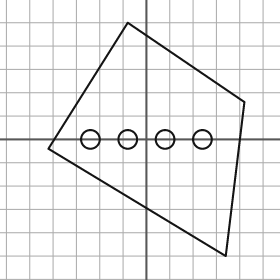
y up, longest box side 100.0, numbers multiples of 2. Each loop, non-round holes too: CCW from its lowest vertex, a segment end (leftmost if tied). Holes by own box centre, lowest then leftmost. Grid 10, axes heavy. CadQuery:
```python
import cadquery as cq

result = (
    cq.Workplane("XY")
    .moveTo(34.0, -50.0)
    .lineTo(42.0, 16.0)
    .lineTo(-8.0, 50.0)
    .lineTo(-42.0, -4.0)
    .close()
    .moveTo(-24.0, 0.0)
    .circle(4.0)
    .moveTo(-8.0, 0.0)
    .circle(4.0)
    .moveTo(8.0, 0.0)
    .circle(4.0)
    .moveTo(24.0, 0.0)
    .circle(4.0)
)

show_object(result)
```